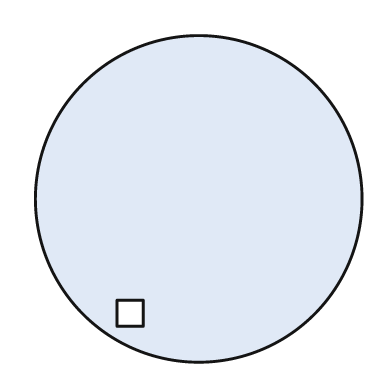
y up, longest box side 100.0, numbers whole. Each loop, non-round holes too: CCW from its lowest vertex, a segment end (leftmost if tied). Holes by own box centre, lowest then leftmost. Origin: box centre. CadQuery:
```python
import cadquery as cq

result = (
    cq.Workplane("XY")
    .moveTo(0.0, 0.0)
    .circle(50.0)
    .moveTo(-25.0, -39.0)
    .lineTo(-17.0, -39.0)
    .lineTo(-17.0, -31.0)
    .lineTo(-25.0, -31.0)
    .close()
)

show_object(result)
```